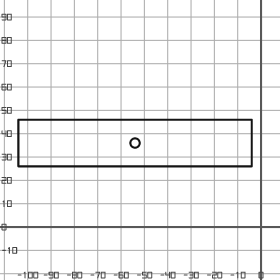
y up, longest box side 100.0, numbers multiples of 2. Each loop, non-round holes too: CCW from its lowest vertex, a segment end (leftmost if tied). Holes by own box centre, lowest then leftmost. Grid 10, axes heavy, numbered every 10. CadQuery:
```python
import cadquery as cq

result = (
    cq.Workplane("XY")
    .moveTo(-104.0, 26.0)
    .lineTo(-4.0, 26.0)
    .lineTo(-4.0, 46.0)
    .lineTo(-104.0, 46.0)
    .close()
    .moveTo(-54.0, 36.0)
    .circle(2.0)
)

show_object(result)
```